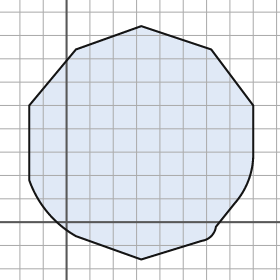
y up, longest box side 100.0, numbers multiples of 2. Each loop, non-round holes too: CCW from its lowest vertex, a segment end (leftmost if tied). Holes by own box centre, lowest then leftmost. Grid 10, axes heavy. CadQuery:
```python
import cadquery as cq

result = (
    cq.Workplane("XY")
    .moveTo(32.0, -16.0)
    .lineTo(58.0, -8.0)
    .threePointArc((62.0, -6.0), (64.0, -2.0))
    .lineTo(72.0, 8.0)
    .threePointArc((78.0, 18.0), (80.0, 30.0))
    .lineTo(80.0, 50.0)
    .lineTo(62.0, 74.0)
    .lineTo(32.0, 84.0)
    .lineTo(4.0, 74.0)
    .lineTo(-16.0, 50.0)
    .lineTo(-16.0, 18.0)
    .threePointArc((-8.0, 4.0), (4.0, -6.0))
    .close()
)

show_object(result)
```